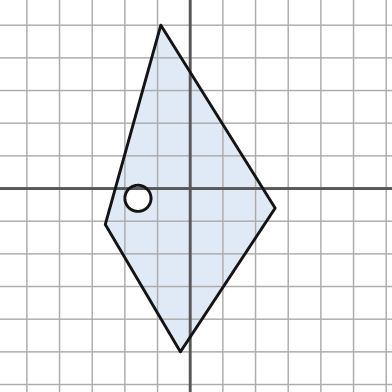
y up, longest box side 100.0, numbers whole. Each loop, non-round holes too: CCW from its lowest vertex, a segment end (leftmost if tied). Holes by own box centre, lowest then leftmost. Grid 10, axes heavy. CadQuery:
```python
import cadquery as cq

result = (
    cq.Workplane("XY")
    .moveTo(-3.0, -50.0)
    .lineTo(26.0, -6.0)
    .lineTo(-9.0, 50.0)
    .lineTo(-26.0, -11.0)
    .close()
    .moveTo(-16.0, -3.0)
    .circle(4.0)
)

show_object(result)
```